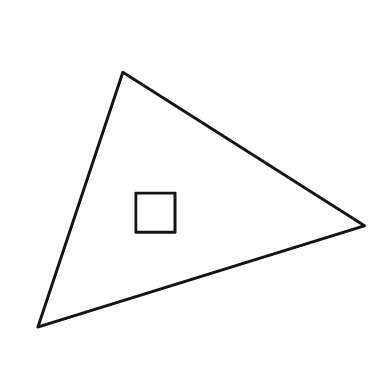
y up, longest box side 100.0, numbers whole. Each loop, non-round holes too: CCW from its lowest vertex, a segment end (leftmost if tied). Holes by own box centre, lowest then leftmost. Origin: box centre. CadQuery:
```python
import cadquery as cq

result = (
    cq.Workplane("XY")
    .moveTo(-50.0, -39.0)
    .lineTo(50.0, -8.0)
    .lineTo(-24.0, 39.0)
    .close()
    .moveTo(-20.0, -10.0)
    .lineTo(-8.0, -10.0)
    .lineTo(-8.0, 2.0)
    .lineTo(-20.0, 2.0)
    .close()
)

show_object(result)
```